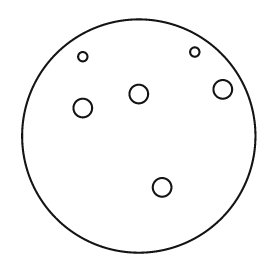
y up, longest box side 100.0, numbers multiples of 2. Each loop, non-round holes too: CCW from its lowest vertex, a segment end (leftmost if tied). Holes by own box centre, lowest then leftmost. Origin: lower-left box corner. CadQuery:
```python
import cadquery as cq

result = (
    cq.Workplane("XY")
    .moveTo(50.0, 50.0)
    .circle(50.0)
    .moveTo(60.0, 28.0)
    .circle(4.0)
    .moveTo(26.0, 62.0)
    .circle(4.0)
    .moveTo(50.0, 68.0)
    .circle(4.0)
    .moveTo(86.0, 70.0)
    .circle(4.0)
    .moveTo(26.0, 84.0)
    .circle(2.0)
    .moveTo(74.0, 86.0)
    .circle(2.0)
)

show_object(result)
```